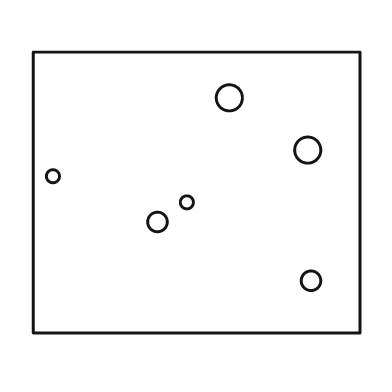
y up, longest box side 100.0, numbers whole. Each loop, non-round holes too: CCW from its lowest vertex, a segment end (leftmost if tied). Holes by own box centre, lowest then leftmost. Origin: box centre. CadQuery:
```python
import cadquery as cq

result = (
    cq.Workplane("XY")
    .moveTo(-50.0, -43.0)
    .lineTo(50.0, -43.0)
    .lineTo(50.0, 43.0)
    .lineTo(-50.0, 43.0)
    .close()
    .moveTo(35.0, -27.0)
    .circle(3.0)
    .moveTo(-12.0, -9.0)
    .circle(3.0)
    .moveTo(-3.0, -3.0)
    .circle(2.0)
    .moveTo(-44.0, 5.0)
    .circle(2.0)
    .moveTo(34.0, 13.0)
    .circle(4.0)
    .moveTo(10.0, 29.0)
    .circle(4.0)
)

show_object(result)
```